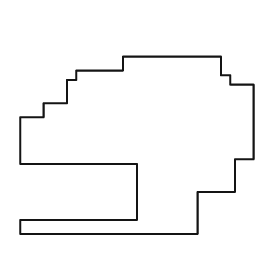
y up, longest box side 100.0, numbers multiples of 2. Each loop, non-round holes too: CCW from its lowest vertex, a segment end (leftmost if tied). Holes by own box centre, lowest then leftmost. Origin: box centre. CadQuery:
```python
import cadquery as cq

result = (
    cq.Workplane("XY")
    .moveTo(-50.0, -38.0)
    .lineTo(26.0, -38.0)
    .lineTo(26.0, -20.0)
    .lineTo(42.0, -20.0)
    .lineTo(42.0, -6.0)
    .lineTo(50.0, -6.0)
    .lineTo(50.0, 26.0)
    .lineTo(40.0, 26.0)
    .lineTo(40.0, 30.0)
    .lineTo(36.0, 30.0)
    .lineTo(36.0, 38.0)
    .lineTo(-6.0, 38.0)
    .lineTo(-6.0, 32.0)
    .lineTo(-26.0, 32.0)
    .lineTo(-26.0, 28.0)
    .lineTo(-30.0, 28.0)
    .lineTo(-30.0, 18.0)
    .lineTo(-40.0, 18.0)
    .lineTo(-40.0, 12.0)
    .lineTo(-50.0, 12.0)
    .lineTo(-50.0, -8.0)
    .lineTo(0.0, -8.0)
    .lineTo(0.0, -32.0)
    .lineTo(-50.0, -32.0)
    .close()
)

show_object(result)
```